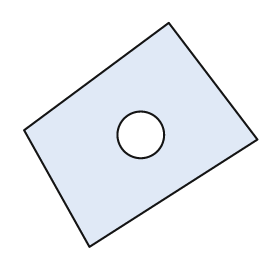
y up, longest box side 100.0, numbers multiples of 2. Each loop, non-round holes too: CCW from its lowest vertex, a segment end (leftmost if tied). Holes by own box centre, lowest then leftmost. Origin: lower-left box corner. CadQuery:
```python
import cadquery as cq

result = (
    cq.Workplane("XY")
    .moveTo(28.0, 0.0)
    .lineTo(100.0, 46.0)
    .lineTo(62.0, 96.0)
    .lineTo(0.0, 50.0)
    .close()
    .moveTo(50.0, 48.0)
    .circle(10.0)
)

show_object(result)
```